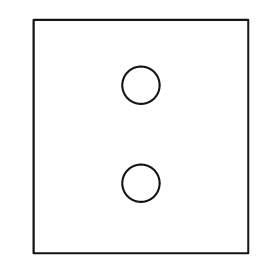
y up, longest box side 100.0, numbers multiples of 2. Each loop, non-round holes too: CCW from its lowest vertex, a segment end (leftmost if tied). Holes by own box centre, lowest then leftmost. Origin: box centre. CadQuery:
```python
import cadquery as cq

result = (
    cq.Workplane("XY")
    .moveTo(-46.0, -50.0)
    .lineTo(46.0, -50.0)
    .lineTo(46.0, 50.0)
    .lineTo(-46.0, 50.0)
    .close()
    .moveTo(0.0, -20.0)
    .circle(8.0)
    .moveTo(0.0, 22.0)
    .circle(8.0)
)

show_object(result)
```